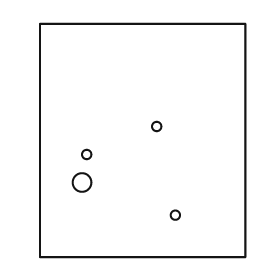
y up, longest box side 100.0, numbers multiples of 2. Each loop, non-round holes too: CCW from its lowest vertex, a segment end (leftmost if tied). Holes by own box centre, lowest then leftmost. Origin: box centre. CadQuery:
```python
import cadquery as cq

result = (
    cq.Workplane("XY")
    .moveTo(-44.0, -50.0)
    .lineTo(44.0, -50.0)
    .lineTo(44.0, 50.0)
    .lineTo(-44.0, 50.0)
    .close()
    .moveTo(14.0, -32.0)
    .circle(2.0)
    .moveTo(-26.0, -18.0)
    .circle(4.0)
    .moveTo(-24.0, -6.0)
    .circle(2.0)
    .moveTo(6.0, 6.0)
    .circle(2.0)
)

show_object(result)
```